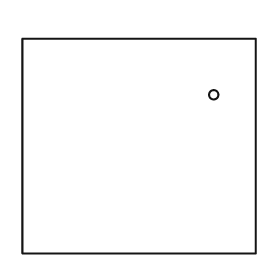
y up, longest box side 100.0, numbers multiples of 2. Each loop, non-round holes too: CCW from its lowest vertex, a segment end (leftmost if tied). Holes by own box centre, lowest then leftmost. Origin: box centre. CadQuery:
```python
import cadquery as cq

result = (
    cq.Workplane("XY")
    .moveTo(-50.0, -46.0)
    .lineTo(50.0, -46.0)
    .lineTo(50.0, 46.0)
    .lineTo(-50.0, 46.0)
    .close()
    .moveTo(32.0, 22.0)
    .circle(2.0)
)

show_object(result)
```